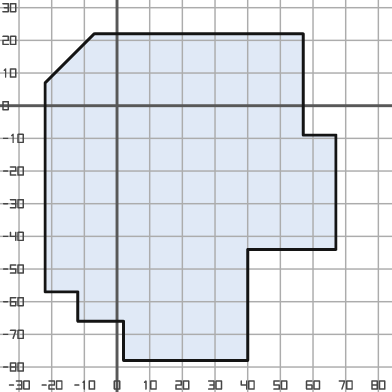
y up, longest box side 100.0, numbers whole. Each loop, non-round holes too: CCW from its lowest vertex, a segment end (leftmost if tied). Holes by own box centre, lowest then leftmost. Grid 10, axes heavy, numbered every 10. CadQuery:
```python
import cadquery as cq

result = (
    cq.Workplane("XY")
    .moveTo(2.0, -78.0)
    .lineTo(40.0, -78.0)
    .lineTo(40.0, -44.0)
    .lineTo(67.0, -44.0)
    .lineTo(67.0, -9.0)
    .lineTo(57.0, -9.0)
    .lineTo(57.0, 22.0)
    .lineTo(-7.0, 22.0)
    .lineTo(-22.0, 7.0)
    .lineTo(-22.0, -57.0)
    .lineTo(-12.0, -57.0)
    .lineTo(-12.0, -66.0)
    .lineTo(2.0, -66.0)
    .close()
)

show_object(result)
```